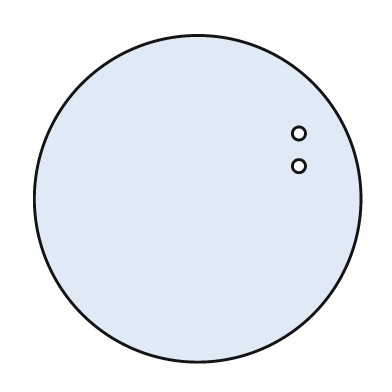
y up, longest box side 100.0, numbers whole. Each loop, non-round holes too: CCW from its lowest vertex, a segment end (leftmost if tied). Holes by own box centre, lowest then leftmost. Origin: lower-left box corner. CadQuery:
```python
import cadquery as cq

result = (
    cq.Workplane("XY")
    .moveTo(50.0, 50.0)
    .circle(50.0)
    .moveTo(81.0, 60.0)
    .circle(2.0)
    .moveTo(81.0, 70.0)
    .circle(2.0)
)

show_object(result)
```